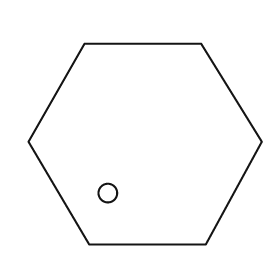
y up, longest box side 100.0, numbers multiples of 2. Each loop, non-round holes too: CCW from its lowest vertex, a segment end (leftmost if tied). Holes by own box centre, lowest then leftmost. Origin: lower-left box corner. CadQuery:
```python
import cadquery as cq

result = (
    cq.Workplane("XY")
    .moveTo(26.0, 0.0)
    .lineTo(76.0, 0.0)
    .lineTo(100.0, 44.0)
    .lineTo(74.0, 86.0)
    .lineTo(24.0, 86.0)
    .lineTo(0.0, 44.0)
    .close()
    .moveTo(34.0, 22.0)
    .circle(4.0)
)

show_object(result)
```